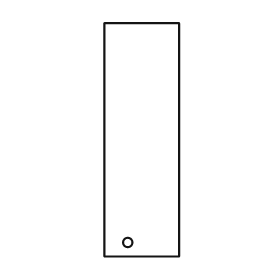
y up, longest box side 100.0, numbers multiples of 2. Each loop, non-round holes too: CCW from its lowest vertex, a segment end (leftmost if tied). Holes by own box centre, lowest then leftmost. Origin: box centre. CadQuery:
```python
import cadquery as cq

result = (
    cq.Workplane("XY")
    .moveTo(-16.0, -50.0)
    .lineTo(16.0, -50.0)
    .lineTo(16.0, 50.0)
    .lineTo(-16.0, 50.0)
    .close()
    .moveTo(-6.0, -44.0)
    .circle(2.0)
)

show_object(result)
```